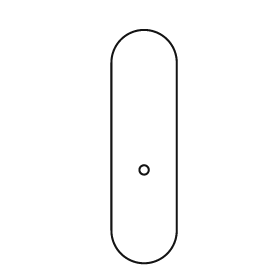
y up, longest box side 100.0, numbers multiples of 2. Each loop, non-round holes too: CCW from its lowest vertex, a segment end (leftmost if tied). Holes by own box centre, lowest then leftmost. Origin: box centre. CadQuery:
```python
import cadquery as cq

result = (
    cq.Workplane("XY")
    .moveTo(-14.0, -36.0)
    .threePointArc((0.0, -50.0), (14.0, -36.0))
    .lineTo(14.0, 36.0)
    .threePointArc((0.0, 50.0), (-14.0, 36.0))
    .close()
    .moveTo(0.0, -10.0)
    .circle(2.0)
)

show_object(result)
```